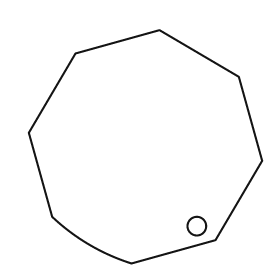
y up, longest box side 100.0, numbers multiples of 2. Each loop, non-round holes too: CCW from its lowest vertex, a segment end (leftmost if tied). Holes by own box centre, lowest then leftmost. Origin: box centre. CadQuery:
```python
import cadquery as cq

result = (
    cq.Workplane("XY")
    .moveTo(-6.0, -50.0)
    .lineTo(30.0, -40.0)
    .lineTo(50.0, -6.0)
    .lineTo(40.0, 30.0)
    .lineTo(6.0, 50.0)
    .lineTo(-30.0, 40.0)
    .lineTo(-50.0, 6.0)
    .lineTo(-40.0, -30.0)
    .threePointArc((-24.0, -42.0), (-6.0, -50.0))
    .close()
    .moveTo(22.0, -34.0)
    .circle(4.0)
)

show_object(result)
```